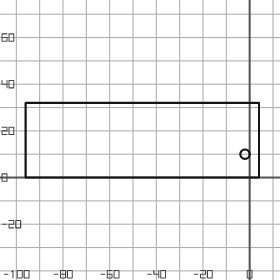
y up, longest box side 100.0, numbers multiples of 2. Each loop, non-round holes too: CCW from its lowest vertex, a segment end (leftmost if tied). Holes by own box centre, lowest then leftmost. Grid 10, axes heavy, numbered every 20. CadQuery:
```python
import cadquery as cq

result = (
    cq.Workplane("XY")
    .moveTo(-96.0, 0.0)
    .lineTo(4.0, 0.0)
    .lineTo(4.0, 32.0)
    .lineTo(-96.0, 32.0)
    .close()
    .moveTo(-2.0, 10.0)
    .circle(2.0)
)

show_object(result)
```